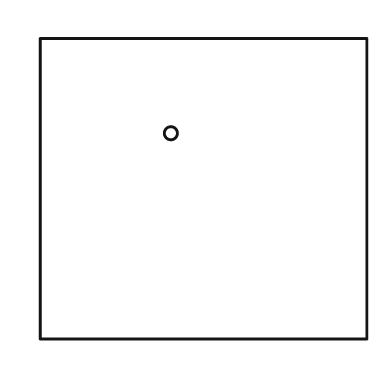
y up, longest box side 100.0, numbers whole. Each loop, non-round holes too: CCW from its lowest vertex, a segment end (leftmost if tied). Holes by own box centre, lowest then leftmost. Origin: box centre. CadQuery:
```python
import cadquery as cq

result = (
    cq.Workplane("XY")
    .moveTo(-50.0, -46.0)
    .lineTo(50.0, -46.0)
    .lineTo(50.0, 46.0)
    .lineTo(-50.0, 46.0)
    .close()
    .moveTo(-10.0, 17.0)
    .circle(2.0)
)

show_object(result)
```